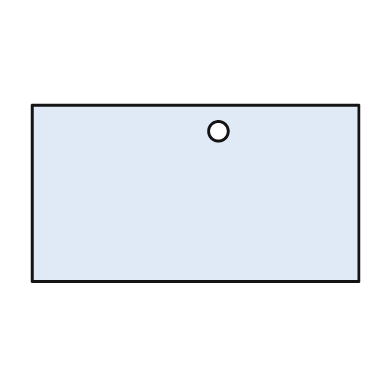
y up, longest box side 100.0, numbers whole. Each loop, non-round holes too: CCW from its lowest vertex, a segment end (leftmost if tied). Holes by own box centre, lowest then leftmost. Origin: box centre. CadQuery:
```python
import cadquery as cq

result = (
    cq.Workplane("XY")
    .moveTo(-50.0, -27.0)
    .lineTo(50.0, -27.0)
    .lineTo(50.0, 27.0)
    .lineTo(-50.0, 27.0)
    .close()
    .moveTo(7.0, 19.0)
    .circle(3.0)
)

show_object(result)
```